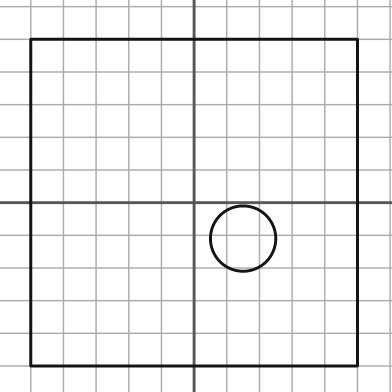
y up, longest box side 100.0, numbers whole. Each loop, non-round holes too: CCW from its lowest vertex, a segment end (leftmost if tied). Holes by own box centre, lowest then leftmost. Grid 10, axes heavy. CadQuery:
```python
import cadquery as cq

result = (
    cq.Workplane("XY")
    .moveTo(-50.0, -50.0)
    .lineTo(50.0, -50.0)
    .lineTo(50.0, 50.0)
    .lineTo(-50.0, 50.0)
    .close()
    .moveTo(15.0, -11.0)
    .circle(10.0)
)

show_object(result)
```